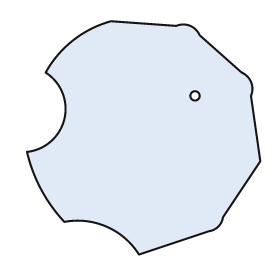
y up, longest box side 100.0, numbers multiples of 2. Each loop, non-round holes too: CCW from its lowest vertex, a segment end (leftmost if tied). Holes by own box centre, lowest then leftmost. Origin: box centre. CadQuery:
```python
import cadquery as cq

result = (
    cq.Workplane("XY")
    .moveTo(-2.0, -50.0)
    .lineTo(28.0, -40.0)
    .threePointArc((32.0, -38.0), (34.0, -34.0))
    .lineTo(50.0, -10.0)
    .lineTo(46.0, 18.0)
    .threePointArc((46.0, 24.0), (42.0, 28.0))
    .lineTo(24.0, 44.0)
    .threePointArc((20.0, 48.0), (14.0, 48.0))
    .lineTo(-14.0, 50.0)
    .threePointArc((-30.0, 42.0), (-42.0, 28.0))
    .threePointArc((-34.0, 8.0), (-50.0, -6.0))
    .threePointArc((-44.0, -22.0), (-34.0, -36.0))
    .threePointArc((-16.0, -38.0), (-2.0, -50.0))
    .close()
    .moveTo(22.0, 18.0)
    .circle(2.0)
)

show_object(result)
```